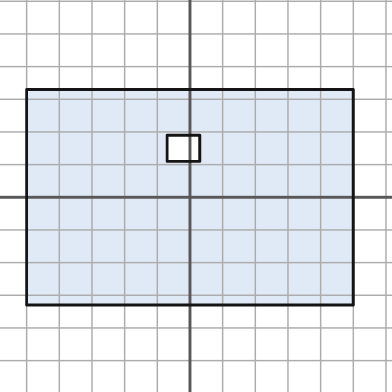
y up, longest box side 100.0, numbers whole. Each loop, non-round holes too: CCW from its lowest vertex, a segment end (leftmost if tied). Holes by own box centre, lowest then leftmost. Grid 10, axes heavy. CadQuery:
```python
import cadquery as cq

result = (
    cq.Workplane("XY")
    .moveTo(-50.0, -33.0)
    .lineTo(50.0, -33.0)
    .lineTo(50.0, 33.0)
    .lineTo(-50.0, 33.0)
    .close()
    .moveTo(-7.0, 11.0)
    .lineTo(3.0, 11.0)
    .lineTo(3.0, 19.0)
    .lineTo(-7.0, 19.0)
    .close()
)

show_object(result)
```